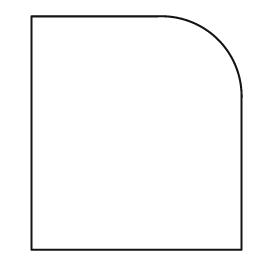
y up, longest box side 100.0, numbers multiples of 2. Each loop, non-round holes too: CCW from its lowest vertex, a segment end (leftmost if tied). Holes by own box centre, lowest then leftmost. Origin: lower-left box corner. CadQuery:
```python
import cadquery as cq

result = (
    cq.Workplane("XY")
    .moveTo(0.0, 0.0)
    .lineTo(90.0, 0.0)
    .lineTo(90.0, 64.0)
    .threePointArc((80.0, 90.0), (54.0, 100.0))
    .lineTo(0.0, 100.0)
    .close()
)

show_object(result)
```